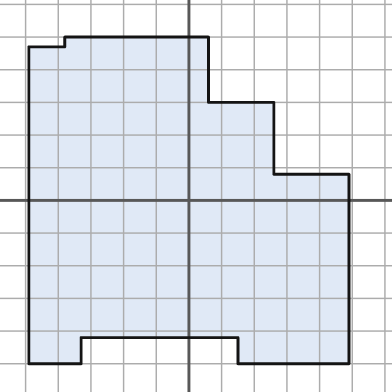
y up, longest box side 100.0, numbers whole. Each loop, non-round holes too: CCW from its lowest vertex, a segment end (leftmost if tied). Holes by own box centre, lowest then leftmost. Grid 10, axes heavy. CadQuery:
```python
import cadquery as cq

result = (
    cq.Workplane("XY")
    .moveTo(-49.0, -50.0)
    .lineTo(-33.0, -50.0)
    .lineTo(-33.0, -42.0)
    .lineTo(15.0, -42.0)
    .lineTo(15.0, -50.0)
    .lineTo(49.0, -50.0)
    .lineTo(49.0, 8.0)
    .lineTo(26.0, 8.0)
    .lineTo(26.0, 30.0)
    .lineTo(6.0, 30.0)
    .lineTo(6.0, 50.0)
    .lineTo(-38.0, 50.0)
    .lineTo(-38.0, 47.0)
    .lineTo(-49.0, 47.0)
    .close()
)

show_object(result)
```